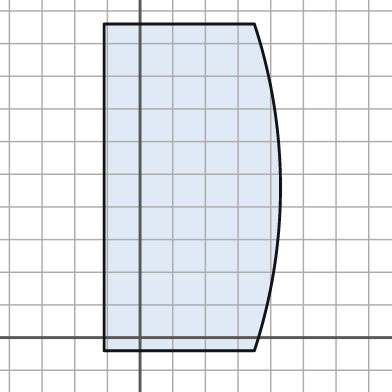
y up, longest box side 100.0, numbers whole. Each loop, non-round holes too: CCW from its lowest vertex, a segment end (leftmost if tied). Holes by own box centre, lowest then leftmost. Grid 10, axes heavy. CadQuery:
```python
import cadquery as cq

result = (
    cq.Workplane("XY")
    .moveTo(-11.0, -4.0)
    .lineTo(35.0, -4.0)
    .threePointArc((43.0, 46.0), (35.0, 96.0))
    .lineTo(-11.0, 96.0)
    .close()
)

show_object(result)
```